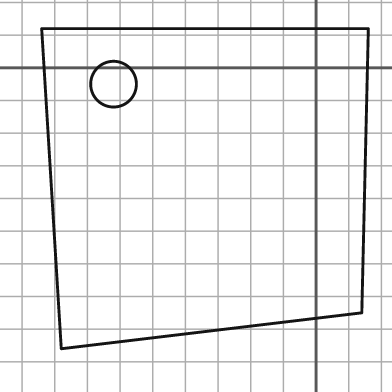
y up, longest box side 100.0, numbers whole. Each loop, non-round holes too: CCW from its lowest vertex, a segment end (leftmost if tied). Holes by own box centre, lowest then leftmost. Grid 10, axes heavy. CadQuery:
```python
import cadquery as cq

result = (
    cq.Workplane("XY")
    .moveTo(-78.0, -86.0)
    .lineTo(14.0, -75.0)
    .lineTo(16.0, 12.0)
    .lineTo(-84.0, 12.0)
    .close()
    .moveTo(-62.0, -5.0)
    .circle(7.0)
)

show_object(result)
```